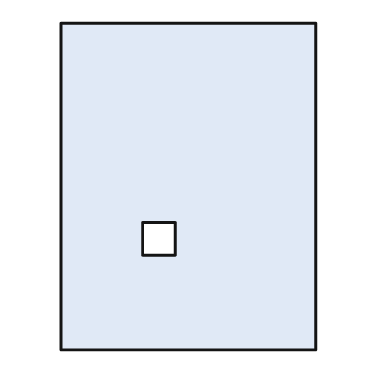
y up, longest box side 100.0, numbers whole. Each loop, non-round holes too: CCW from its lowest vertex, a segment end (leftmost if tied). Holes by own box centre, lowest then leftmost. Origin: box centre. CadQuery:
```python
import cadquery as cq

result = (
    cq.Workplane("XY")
    .moveTo(-39.0, -50.0)
    .lineTo(39.0, -50.0)
    .lineTo(39.0, 50.0)
    .lineTo(-39.0, 50.0)
    .close()
    .moveTo(-14.0, -21.0)
    .lineTo(-4.0, -21.0)
    .lineTo(-4.0, -11.0)
    .lineTo(-14.0, -11.0)
    .close()
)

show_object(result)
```